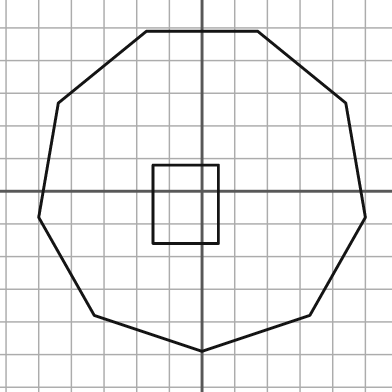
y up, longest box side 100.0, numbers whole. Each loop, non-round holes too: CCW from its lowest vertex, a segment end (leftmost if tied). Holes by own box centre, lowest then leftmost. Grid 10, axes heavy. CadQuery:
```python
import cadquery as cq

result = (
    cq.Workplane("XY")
    .moveTo(0.0, -49.0)
    .lineTo(33.0, -38.0)
    .lineTo(50.0, -8.0)
    .lineTo(44.0, 27.0)
    .lineTo(17.0, 49.0)
    .lineTo(-17.0, 49.0)
    .lineTo(-44.0, 27.0)
    .lineTo(-50.0, -8.0)
    .lineTo(-33.0, -38.0)
    .close()
    .moveTo(-15.0, -16.0)
    .lineTo(5.0, -16.0)
    .lineTo(5.0, 8.0)
    .lineTo(-15.0, 8.0)
    .close()
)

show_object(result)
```